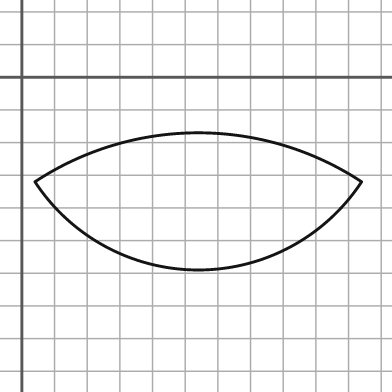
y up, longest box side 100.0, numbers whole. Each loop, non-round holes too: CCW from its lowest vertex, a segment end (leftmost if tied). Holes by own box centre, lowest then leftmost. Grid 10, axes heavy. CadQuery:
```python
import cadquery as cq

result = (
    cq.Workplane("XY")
    .moveTo(4.0, -32.0)
    .threePointArc((54.0, -59.0), (104.0, -32.0))
    .threePointArc((54.0, -17.0), (4.0, -32.0))
    .close()
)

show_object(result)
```